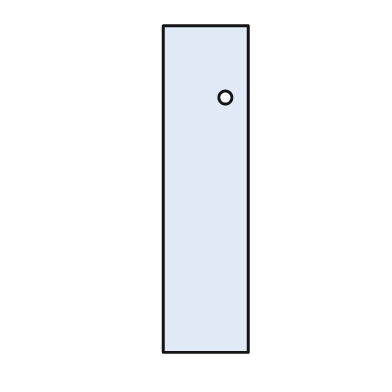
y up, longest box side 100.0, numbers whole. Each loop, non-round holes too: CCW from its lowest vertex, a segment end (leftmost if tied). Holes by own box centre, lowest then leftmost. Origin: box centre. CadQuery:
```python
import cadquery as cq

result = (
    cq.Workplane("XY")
    .moveTo(-13.0, -50.0)
    .lineTo(13.0, -50.0)
    .lineTo(13.0, 50.0)
    .lineTo(-13.0, 50.0)
    .close()
    .moveTo(6.0, 28.0)
    .circle(2.0)
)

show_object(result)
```